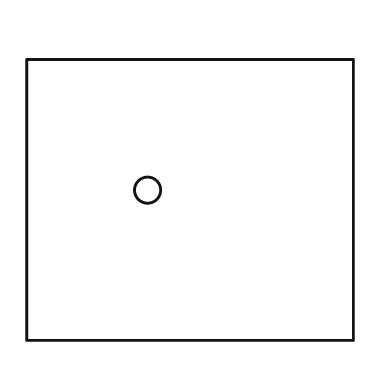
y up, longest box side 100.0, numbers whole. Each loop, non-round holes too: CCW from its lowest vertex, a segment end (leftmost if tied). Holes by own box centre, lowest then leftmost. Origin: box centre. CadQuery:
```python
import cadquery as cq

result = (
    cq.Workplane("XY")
    .moveTo(-50.0, -43.0)
    .lineTo(50.0, -43.0)
    .lineTo(50.0, 43.0)
    .lineTo(-50.0, 43.0)
    .close()
    .moveTo(-13.0, 3.0)
    .circle(4.0)
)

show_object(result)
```